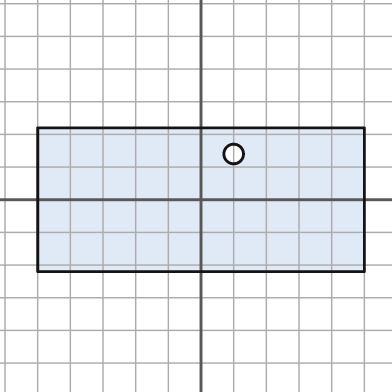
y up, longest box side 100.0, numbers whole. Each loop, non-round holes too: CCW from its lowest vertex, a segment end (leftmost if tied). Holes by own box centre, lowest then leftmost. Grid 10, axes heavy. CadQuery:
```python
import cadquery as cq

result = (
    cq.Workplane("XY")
    .moveTo(-50.0, -22.0)
    .lineTo(50.0, -22.0)
    .lineTo(50.0, 22.0)
    .lineTo(-50.0, 22.0)
    .close()
    .moveTo(10.0, 14.0)
    .circle(3.0)
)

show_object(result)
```